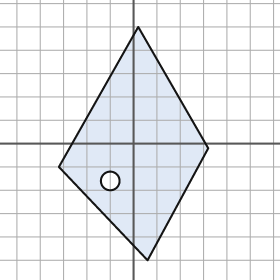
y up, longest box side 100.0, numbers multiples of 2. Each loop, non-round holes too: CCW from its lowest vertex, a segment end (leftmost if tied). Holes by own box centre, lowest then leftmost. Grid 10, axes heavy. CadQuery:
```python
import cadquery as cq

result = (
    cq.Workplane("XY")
    .moveTo(6.0, -50.0)
    .lineTo(32.0, -2.0)
    .lineTo(2.0, 50.0)
    .lineTo(-32.0, -10.0)
    .close()
    .moveTo(-10.0, -16.0)
    .circle(4.0)
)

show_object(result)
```